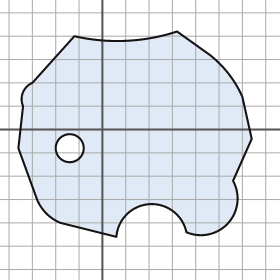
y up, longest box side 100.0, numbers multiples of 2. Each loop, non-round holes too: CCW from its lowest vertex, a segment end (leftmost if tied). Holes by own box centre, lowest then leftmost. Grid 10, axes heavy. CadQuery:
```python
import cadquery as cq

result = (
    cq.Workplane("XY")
    .moveTo(6.0, -46.0)
    .threePointArc((20.0, -32.0), (36.0, -44.0))
    .threePointArc((54.0, -40.0), (56.0, -22.0))
    .lineTo(64.0, -4.0)
    .lineTo(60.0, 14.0)
    .threePointArc((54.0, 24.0), (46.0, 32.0))
    .lineTo(32.0, 42.0)
    .threePointArc((10.0, 38.0), (-12.0, 40.0))
    .lineTo(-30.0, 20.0)
    .threePointArc((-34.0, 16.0), (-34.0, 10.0))
    .lineTo(-36.0, -8.0)
    .lineTo(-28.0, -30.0)
    .threePointArc((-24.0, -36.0), (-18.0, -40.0))
    .close()
    .moveTo(-14.0, -8.0)
    .circle(6.0)
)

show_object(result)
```